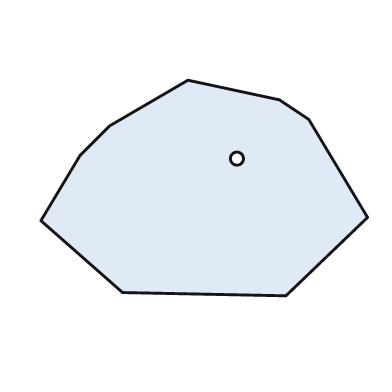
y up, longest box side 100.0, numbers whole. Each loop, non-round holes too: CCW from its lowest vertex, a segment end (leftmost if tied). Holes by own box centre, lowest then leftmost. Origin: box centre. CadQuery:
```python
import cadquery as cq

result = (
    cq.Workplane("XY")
    .moveTo(25.0, -33.0)
    .lineTo(50.0, -9.0)
    .lineTo(32.0, 21.0)
    .lineTo(23.0, 27.0)
    .lineTo(-5.0, 33.0)
    .lineTo(-29.0, 19.0)
    .lineTo(-38.0, 10.0)
    .lineTo(-50.0, -10.0)
    .lineTo(-25.0, -32.0)
    .close()
    .moveTo(10.0, 9.0)
    .circle(2.0)
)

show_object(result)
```